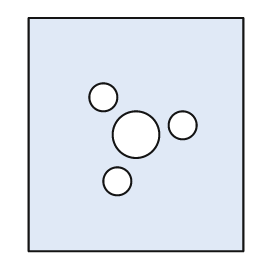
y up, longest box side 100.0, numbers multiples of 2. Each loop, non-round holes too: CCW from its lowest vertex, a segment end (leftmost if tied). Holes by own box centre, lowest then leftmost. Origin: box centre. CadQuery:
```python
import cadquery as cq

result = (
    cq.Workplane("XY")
    .moveTo(-46.0, -50.0)
    .lineTo(46.0, -50.0)
    .lineTo(46.0, 50.0)
    .lineTo(-46.0, 50.0)
    .close()
    .moveTo(-8.0, -20.0)
    .circle(6.0)
    .moveTo(0.0, 0.0)
    .circle(10.0)
    .moveTo(20.0, 4.0)
    .circle(6.0)
    .moveTo(-14.0, 16.0)
    .circle(6.0)
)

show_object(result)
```